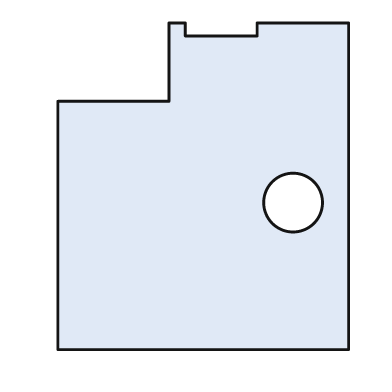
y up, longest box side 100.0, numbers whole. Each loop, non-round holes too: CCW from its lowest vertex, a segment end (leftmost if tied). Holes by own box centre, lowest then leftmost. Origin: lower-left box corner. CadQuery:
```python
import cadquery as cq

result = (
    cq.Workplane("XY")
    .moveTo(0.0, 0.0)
    .lineTo(89.0, 0.0)
    .lineTo(89.0, 100.0)
    .lineTo(61.0, 100.0)
    .lineTo(61.0, 96.0)
    .lineTo(39.0, 96.0)
    .lineTo(39.0, 100.0)
    .lineTo(34.0, 100.0)
    .lineTo(34.0, 76.0)
    .lineTo(0.0, 76.0)
    .close()
    .moveTo(72.0, 45.0)
    .circle(9.0)
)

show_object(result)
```